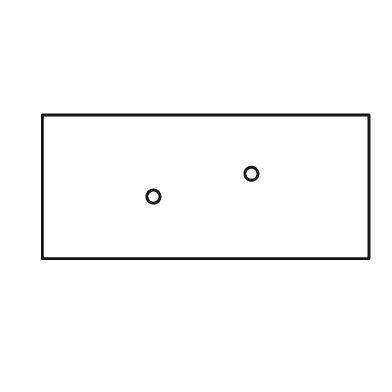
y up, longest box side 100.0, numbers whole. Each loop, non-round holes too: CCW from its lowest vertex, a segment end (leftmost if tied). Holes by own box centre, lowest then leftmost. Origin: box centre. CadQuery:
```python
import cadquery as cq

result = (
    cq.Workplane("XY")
    .moveTo(-50.0, -22.0)
    .lineTo(50.0, -22.0)
    .lineTo(50.0, 22.0)
    .lineTo(-50.0, 22.0)
    .close()
    .moveTo(-16.0, -3.0)
    .circle(2.0)
    .moveTo(14.0, 4.0)
    .circle(2.0)
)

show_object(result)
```